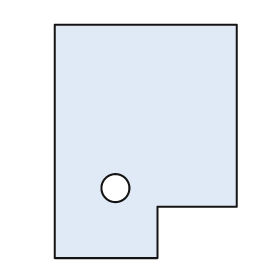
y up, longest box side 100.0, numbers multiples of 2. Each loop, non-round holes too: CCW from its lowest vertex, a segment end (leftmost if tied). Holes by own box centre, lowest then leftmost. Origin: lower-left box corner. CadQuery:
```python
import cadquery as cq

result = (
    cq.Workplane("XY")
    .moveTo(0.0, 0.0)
    .lineTo(44.0, 0.0)
    .lineTo(44.0, 22.0)
    .lineTo(78.0, 22.0)
    .lineTo(78.0, 100.0)
    .lineTo(0.0, 100.0)
    .close()
    .moveTo(26.0, 30.0)
    .circle(6.0)
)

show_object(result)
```